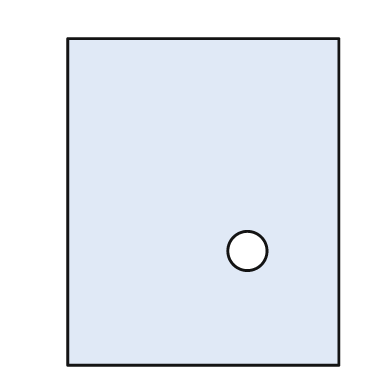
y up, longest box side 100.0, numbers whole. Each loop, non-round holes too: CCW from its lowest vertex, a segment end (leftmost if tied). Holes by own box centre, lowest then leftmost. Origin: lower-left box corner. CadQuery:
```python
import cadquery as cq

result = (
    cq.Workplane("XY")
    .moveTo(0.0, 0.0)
    .lineTo(83.0, 0.0)
    .lineTo(83.0, 100.0)
    .lineTo(0.0, 100.0)
    .close()
    .moveTo(55.0, 35.0)
    .circle(6.0)
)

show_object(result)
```